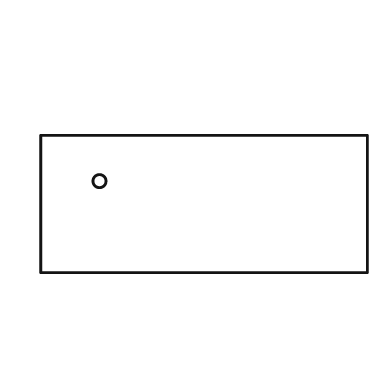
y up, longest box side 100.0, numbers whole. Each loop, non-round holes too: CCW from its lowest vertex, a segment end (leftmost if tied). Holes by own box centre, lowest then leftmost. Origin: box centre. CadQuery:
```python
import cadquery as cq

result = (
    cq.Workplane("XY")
    .moveTo(-50.0, -21.0)
    .lineTo(50.0, -21.0)
    .lineTo(50.0, 21.0)
    .lineTo(-50.0, 21.0)
    .close()
    .moveTo(-32.0, 7.0)
    .circle(2.0)
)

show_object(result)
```